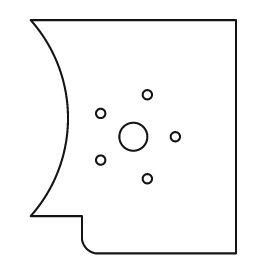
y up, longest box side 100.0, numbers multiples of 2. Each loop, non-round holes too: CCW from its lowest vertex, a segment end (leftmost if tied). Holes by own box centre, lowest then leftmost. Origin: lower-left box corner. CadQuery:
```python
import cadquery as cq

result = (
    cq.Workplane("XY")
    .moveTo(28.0, 0.0)
    .lineTo(88.0, 0.0)
    .lineTo(88.0, 100.0)
    .lineTo(0.0, 100.0)
    .threePointArc((16.0, 58.0), (0.0, 16.0))
    .lineTo(22.0, 16.0)
    .lineTo(22.0, 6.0)
    .threePointArc((24.0, 2.0), (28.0, 0.0))
    .close()
    .moveTo(50.0, 32.0)
    .circle(2.0)
    .moveTo(30.0, 40.0)
    .circle(2.0)
    .moveTo(44.0, 50.0)
    .circle(6.0)
    .moveTo(62.0, 50.0)
    .circle(2.0)
    .moveTo(30.0, 60.0)
    .circle(2.0)
    .moveTo(50.0, 68.0)
    .circle(2.0)
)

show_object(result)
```